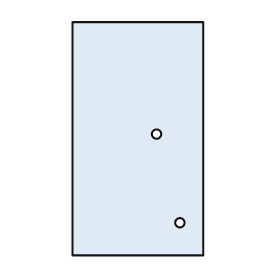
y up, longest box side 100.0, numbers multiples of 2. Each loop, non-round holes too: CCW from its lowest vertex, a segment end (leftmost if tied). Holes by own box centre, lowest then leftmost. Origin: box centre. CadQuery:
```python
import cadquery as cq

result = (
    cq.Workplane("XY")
    .moveTo(-28.0, -50.0)
    .lineTo(28.0, -50.0)
    .lineTo(28.0, 50.0)
    .lineTo(-28.0, 50.0)
    .close()
    .moveTo(18.0, -36.0)
    .circle(2.0)
    .moveTo(8.0, 2.0)
    .circle(2.0)
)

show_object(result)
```